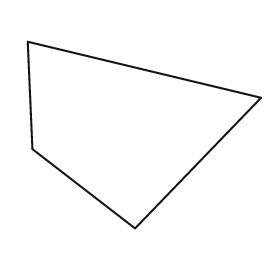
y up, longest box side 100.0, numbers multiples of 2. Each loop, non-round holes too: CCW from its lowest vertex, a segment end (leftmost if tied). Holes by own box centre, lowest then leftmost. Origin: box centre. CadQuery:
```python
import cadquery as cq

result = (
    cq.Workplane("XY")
    .moveTo(-4.0, -40.0)
    .lineTo(50.0, 16.0)
    .lineTo(-50.0, 40.0)
    .lineTo(-48.0, -6.0)
    .close()
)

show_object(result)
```